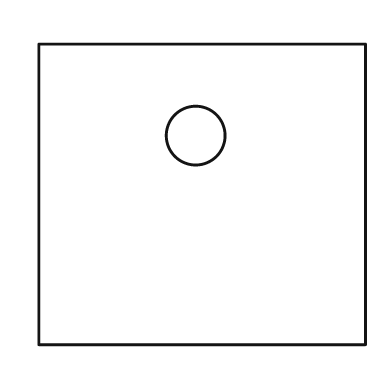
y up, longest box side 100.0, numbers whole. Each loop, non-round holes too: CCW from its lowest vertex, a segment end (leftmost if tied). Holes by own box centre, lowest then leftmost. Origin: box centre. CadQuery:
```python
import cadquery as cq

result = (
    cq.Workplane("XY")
    .moveTo(-50.0, -46.0)
    .lineTo(50.0, -46.0)
    .lineTo(50.0, 46.0)
    .lineTo(-50.0, 46.0)
    .close()
    .moveTo(-2.0, 18.0)
    .circle(9.0)
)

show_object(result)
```